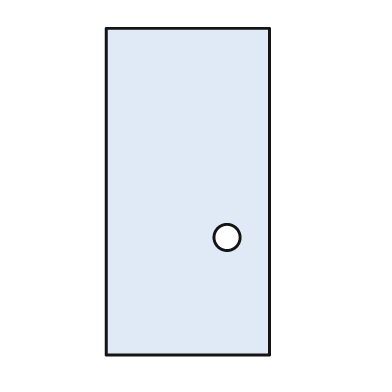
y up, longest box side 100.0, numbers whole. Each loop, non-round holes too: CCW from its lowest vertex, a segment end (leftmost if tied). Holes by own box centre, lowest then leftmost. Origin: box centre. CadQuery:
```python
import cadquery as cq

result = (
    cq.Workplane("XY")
    .moveTo(-25.0, -50.0)
    .lineTo(25.0, -50.0)
    .lineTo(25.0, 50.0)
    .lineTo(-25.0, 50.0)
    .close()
    .moveTo(12.0, -14.0)
    .circle(4.0)
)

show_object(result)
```